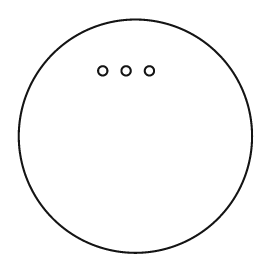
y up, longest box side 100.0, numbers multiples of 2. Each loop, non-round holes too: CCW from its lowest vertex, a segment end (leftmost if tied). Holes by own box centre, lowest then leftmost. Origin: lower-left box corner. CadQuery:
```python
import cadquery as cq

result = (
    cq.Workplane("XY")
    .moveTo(50.0, 50.0)
    .circle(50.0)
    .moveTo(36.0, 78.0)
    .circle(2.0)
    .moveTo(46.0, 78.0)
    .circle(2.0)
    .moveTo(56.0, 78.0)
    .circle(2.0)
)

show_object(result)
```